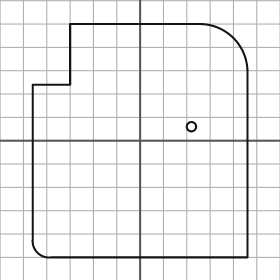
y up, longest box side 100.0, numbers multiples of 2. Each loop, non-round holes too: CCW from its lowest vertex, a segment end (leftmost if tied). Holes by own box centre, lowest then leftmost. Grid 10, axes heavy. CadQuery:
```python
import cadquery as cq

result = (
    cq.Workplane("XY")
    .moveTo(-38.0, -50.0)
    .lineTo(46.0, -50.0)
    .lineTo(46.0, 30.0)
    .threePointArc((40.0, 44.0), (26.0, 50.0))
    .lineTo(-30.0, 50.0)
    .lineTo(-30.0, 24.0)
    .lineTo(-46.0, 24.0)
    .lineTo(-46.0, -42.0)
    .threePointArc((-44.0, -48.0), (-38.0, -50.0))
    .close()
    .moveTo(22.0, 6.0)
    .circle(2.0)
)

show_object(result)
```